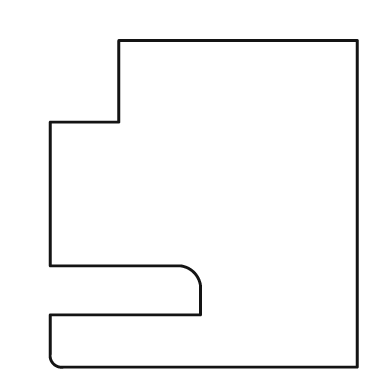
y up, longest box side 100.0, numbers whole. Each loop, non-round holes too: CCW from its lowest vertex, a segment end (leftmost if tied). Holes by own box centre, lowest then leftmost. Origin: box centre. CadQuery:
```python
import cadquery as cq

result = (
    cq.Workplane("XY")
    .moveTo(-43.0, -50.0)
    .lineTo(47.0, -50.0)
    .lineTo(47.0, 50.0)
    .lineTo(-26.0, 50.0)
    .lineTo(-26.0, 25.0)
    .lineTo(-47.0, 25.0)
    .lineTo(-47.0, -19.0)
    .lineTo(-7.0, -19.0)
    .threePointArc((-3.0, -21.0), (-1.0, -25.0))
    .lineTo(-1.0, -34.0)
    .lineTo(-47.0, -34.0)
    .lineTo(-47.0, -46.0)
    .threePointArc((-46.0, -49.0), (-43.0, -50.0))
    .close()
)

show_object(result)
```